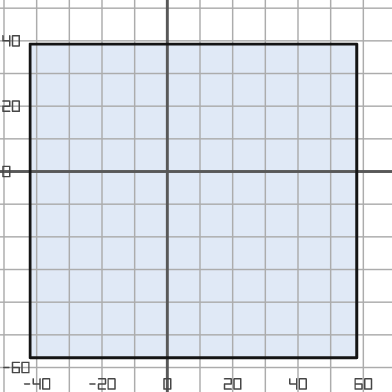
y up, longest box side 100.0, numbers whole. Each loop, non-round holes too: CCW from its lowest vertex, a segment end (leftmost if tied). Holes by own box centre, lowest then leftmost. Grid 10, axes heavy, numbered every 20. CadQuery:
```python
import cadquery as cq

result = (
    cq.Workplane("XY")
    .moveTo(-42.0, -57.0)
    .lineTo(58.0, -57.0)
    .lineTo(58.0, 39.0)
    .lineTo(-42.0, 39.0)
    .close()
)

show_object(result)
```